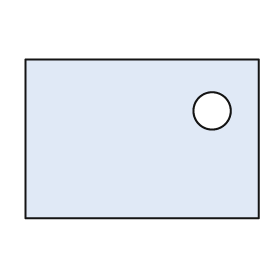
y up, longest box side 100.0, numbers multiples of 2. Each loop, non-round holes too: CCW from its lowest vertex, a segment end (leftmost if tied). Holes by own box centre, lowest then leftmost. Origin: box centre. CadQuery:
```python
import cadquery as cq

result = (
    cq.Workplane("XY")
    .moveTo(-50.0, -34.0)
    .lineTo(50.0, -34.0)
    .lineTo(50.0, 34.0)
    .lineTo(-50.0, 34.0)
    .close()
    .moveTo(30.0, 12.0)
    .circle(8.0)
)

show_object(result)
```